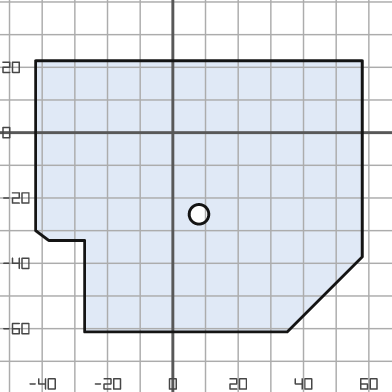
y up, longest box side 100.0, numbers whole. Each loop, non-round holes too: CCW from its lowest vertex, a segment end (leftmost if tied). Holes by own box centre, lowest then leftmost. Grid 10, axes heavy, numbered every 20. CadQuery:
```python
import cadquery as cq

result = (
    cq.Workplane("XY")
    .moveTo(-27.0, -61.0)
    .lineTo(35.0, -61.0)
    .lineTo(58.0, -38.0)
    .lineTo(58.0, 22.0)
    .lineTo(-42.0, 22.0)
    .lineTo(-42.0, -30.0)
    .lineTo(-38.0, -33.0)
    .lineTo(-27.0, -33.0)
    .close()
    .moveTo(8.0, -25.0)
    .circle(3.0)
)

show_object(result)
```